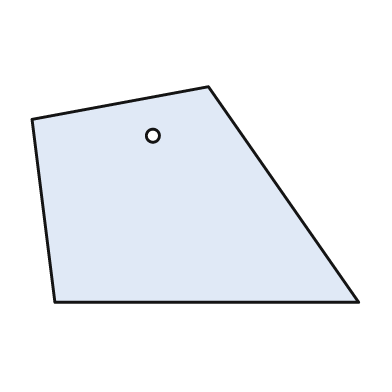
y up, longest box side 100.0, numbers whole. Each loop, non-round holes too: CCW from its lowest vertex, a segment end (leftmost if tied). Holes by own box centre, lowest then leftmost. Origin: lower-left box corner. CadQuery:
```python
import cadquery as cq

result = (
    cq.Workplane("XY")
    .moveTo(7.0, 0.0)
    .lineTo(100.0, 0.0)
    .lineTo(54.0, 66.0)
    .lineTo(0.0, 56.0)
    .close()
    .moveTo(37.0, 51.0)
    .circle(2.0)
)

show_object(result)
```